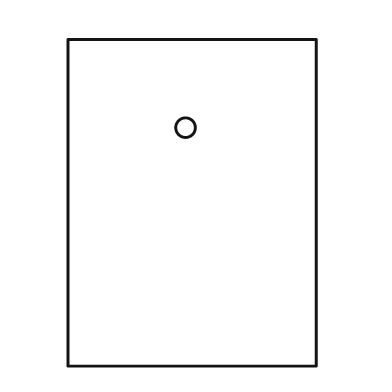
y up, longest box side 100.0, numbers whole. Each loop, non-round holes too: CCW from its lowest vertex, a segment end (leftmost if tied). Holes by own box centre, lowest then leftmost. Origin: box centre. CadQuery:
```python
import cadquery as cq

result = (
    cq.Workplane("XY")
    .moveTo(-38.0, -50.0)
    .lineTo(38.0, -50.0)
    .lineTo(38.0, 50.0)
    .lineTo(-38.0, 50.0)
    .close()
    .moveTo(-2.0, 23.0)
    .circle(3.0)
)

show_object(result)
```